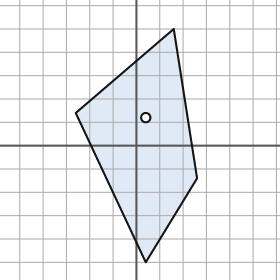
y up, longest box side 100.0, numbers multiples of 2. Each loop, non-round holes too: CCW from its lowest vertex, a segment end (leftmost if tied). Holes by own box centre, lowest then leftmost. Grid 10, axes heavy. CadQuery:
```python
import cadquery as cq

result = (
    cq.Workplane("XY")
    .moveTo(4.0, -50.0)
    .lineTo(26.0, -14.0)
    .lineTo(16.0, 50.0)
    .lineTo(-26.0, 14.0)
    .close()
    .moveTo(4.0, 12.0)
    .circle(2.0)
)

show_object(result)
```